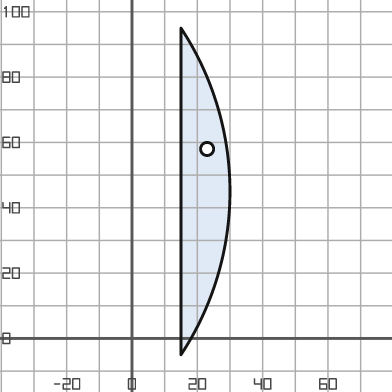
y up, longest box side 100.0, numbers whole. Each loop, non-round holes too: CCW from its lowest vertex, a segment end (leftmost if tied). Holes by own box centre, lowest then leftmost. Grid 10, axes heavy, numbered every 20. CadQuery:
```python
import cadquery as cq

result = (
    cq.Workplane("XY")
    .moveTo(15.0, -5.0)
    .threePointArc((30.0, 45.0), (15.0, 95.0))
    .close()
    .moveTo(23.0, 58.0)
    .circle(2.0)
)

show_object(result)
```